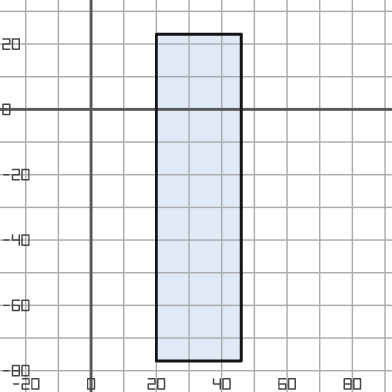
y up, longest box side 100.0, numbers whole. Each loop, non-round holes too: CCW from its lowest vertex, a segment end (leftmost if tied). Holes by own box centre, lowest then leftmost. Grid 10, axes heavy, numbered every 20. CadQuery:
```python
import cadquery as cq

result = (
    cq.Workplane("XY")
    .moveTo(20.0, -77.0)
    .lineTo(46.0, -77.0)
    .lineTo(46.0, 23.0)
    .lineTo(20.0, 23.0)
    .close()
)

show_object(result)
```